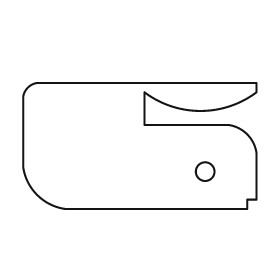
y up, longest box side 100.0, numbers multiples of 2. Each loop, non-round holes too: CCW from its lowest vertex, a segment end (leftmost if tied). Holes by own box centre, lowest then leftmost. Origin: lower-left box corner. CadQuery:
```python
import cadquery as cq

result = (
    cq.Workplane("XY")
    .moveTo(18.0, 0.0)
    .lineTo(96.0, 0.0)
    .lineTo(96.0, 4.0)
    .lineTo(100.0, 4.0)
    .lineTo(100.0, 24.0)
    .threePointArc((96.0, 32.0), (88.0, 36.0))
    .lineTo(52.0, 36.0)
    .lineTo(52.0, 50.0)
    .threePointArc((76.0, 42.0), (100.0, 50.0))
    .lineTo(100.0, 54.0)
    .lineTo(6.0, 54.0)
    .threePointArc((2.0, 52.0), (0.0, 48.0))
    .lineTo(0.0, 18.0)
    .threePointArc((6.0, 6.0), (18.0, 0.0))
    .close()
    .moveTo(78.0, 16.0)
    .circle(4.0)
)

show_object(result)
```